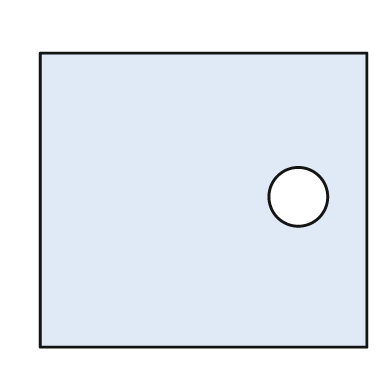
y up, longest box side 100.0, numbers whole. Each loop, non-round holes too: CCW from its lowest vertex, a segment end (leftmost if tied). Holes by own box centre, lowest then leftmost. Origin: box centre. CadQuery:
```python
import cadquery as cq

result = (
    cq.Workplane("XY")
    .moveTo(-50.0, -45.0)
    .lineTo(50.0, -45.0)
    .lineTo(50.0, 45.0)
    .lineTo(-50.0, 45.0)
    .close()
    .moveTo(29.0, 1.0)
    .circle(9.0)
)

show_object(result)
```